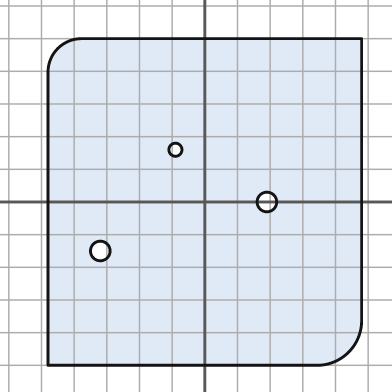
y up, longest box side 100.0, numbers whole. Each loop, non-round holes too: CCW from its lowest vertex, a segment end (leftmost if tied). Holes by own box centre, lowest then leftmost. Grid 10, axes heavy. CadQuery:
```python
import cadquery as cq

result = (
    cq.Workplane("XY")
    .moveTo(-48.0, -50.0)
    .lineTo(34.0, -50.0)
    .threePointArc((44.0, -46.0), (48.0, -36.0))
    .lineTo(48.0, 50.0)
    .lineTo(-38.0, 50.0)
    .threePointArc((-45.0, 47.0), (-48.0, 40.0))
    .close()
    .moveTo(-32.0, -15.0)
    .circle(3.0)
    .moveTo(19.0, 0.0)
    .circle(3.0)
    .moveTo(-9.0, 16.0)
    .circle(2.0)
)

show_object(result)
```